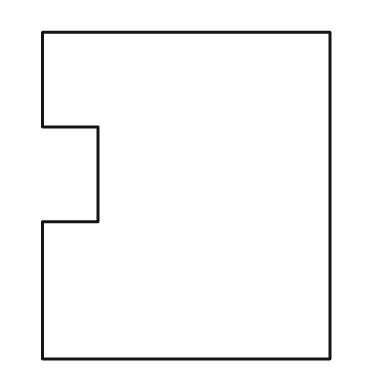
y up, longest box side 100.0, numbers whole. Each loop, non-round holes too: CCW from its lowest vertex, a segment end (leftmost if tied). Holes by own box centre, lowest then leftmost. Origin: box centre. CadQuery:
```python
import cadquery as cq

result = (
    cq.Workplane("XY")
    .moveTo(-44.0, -50.0)
    .lineTo(44.0, -50.0)
    .lineTo(44.0, 50.0)
    .lineTo(-44.0, 50.0)
    .lineTo(-44.0, 21.0)
    .lineTo(-27.0, 21.0)
    .lineTo(-27.0, -8.0)
    .lineTo(-44.0, -8.0)
    .close()
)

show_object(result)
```